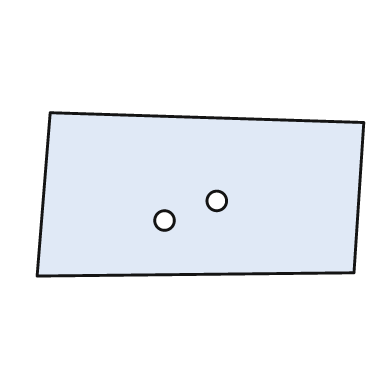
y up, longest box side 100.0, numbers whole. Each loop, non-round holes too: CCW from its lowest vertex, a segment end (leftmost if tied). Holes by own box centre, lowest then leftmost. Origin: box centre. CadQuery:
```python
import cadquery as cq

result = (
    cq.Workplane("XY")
    .moveTo(-50.0, -25.0)
    .lineTo(47.0, -24.0)
    .lineTo(50.0, 22.0)
    .lineTo(-46.0, 25.0)
    .close()
    .moveTo(-11.0, -8.0)
    .circle(3.0)
    .moveTo(5.0, -2.0)
    .circle(3.0)
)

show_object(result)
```